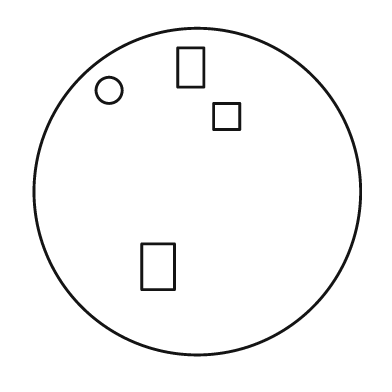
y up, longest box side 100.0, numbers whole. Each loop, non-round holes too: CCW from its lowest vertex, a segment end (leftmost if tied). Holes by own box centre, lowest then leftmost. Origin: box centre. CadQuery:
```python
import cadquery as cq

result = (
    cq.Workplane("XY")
    .moveTo(0.0, 0.0)
    .circle(50.0)
    .moveTo(-17.0, -30.0)
    .lineTo(-7.0, -30.0)
    .lineTo(-7.0, -16.0)
    .lineTo(-17.0, -16.0)
    .close()
    .moveTo(5.0, 19.0)
    .lineTo(13.0, 19.0)
    .lineTo(13.0, 27.0)
    .lineTo(5.0, 27.0)
    .close()
    .moveTo(-27.0, 31.0)
    .circle(4.0)
    .moveTo(-6.0, 32.0)
    .lineTo(2.0, 32.0)
    .lineTo(2.0, 44.0)
    .lineTo(-6.0, 44.0)
    .close()
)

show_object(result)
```